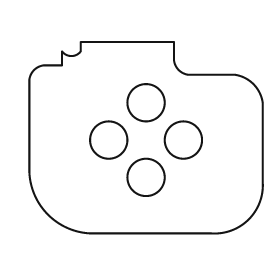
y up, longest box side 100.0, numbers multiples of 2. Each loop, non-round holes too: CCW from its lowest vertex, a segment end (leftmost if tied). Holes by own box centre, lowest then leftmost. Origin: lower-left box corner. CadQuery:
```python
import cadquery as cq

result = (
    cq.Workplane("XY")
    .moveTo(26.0, 0.0)
    .lineTo(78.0, 0.0)
    .threePointArc((94.0, 6.0), (100.0, 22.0))
    .lineTo(100.0, 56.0)
    .threePointArc((96.0, 64.0), (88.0, 68.0))
    .lineTo(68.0, 68.0)
    .threePointArc((64.0, 70.0), (62.0, 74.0))
    .lineTo(62.0, 82.0)
    .lineTo(22.0, 82.0)
    .lineTo(22.0, 78.0)
    .threePointArc((18.0, 76.0), (14.0, 78.0))
    .lineTo(14.0, 72.0)
    .lineTo(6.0, 72.0)
    .threePointArc((2.0, 70.0), (0.0, 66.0))
    .lineTo(0.0, 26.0)
    .threePointArc((8.0, 8.0), (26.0, 0.0))
    .close()
    .moveTo(50.0, 24.0)
    .circle(8.0)
    .moveTo(34.0, 40.0)
    .circle(8.0)
    .moveTo(66.0, 40.0)
    .circle(8.0)
    .moveTo(50.0, 56.0)
    .circle(8.0)
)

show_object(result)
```